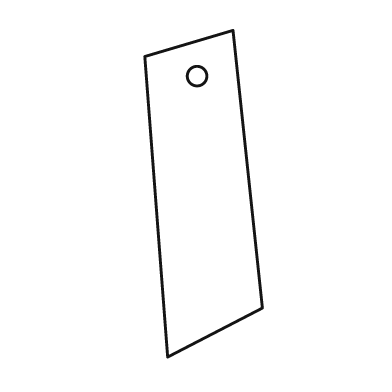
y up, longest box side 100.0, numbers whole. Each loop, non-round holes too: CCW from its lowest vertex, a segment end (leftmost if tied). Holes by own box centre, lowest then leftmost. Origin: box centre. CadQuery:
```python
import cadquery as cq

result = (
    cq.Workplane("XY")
    .moveTo(-11.0, -50.0)
    .lineTo(18.0, -35.0)
    .lineTo(9.0, 50.0)
    .lineTo(-18.0, 42.0)
    .close()
    .moveTo(-2.0, 36.0)
    .circle(3.0)
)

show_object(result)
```